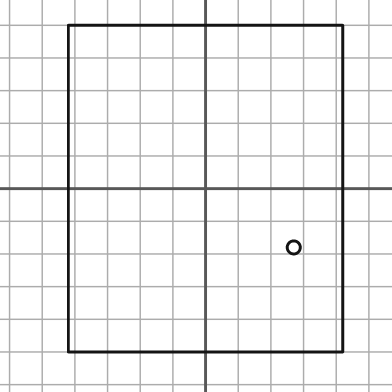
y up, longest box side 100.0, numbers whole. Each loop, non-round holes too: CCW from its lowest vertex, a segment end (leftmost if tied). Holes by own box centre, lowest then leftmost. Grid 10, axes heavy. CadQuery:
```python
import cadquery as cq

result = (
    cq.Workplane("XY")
    .moveTo(-42.0, -50.0)
    .lineTo(42.0, -50.0)
    .lineTo(42.0, 50.0)
    .lineTo(-42.0, 50.0)
    .close()
    .moveTo(27.0, -18.0)
    .circle(2.0)
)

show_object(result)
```